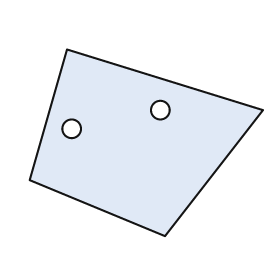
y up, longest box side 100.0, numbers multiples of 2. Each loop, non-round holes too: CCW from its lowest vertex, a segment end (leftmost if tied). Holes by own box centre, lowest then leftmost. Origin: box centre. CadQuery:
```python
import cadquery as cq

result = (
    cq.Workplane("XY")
    .moveTo(8.0, -40.0)
    .lineTo(50.0, 14.0)
    .lineTo(-34.0, 40.0)
    .lineTo(-50.0, -16.0)
    .close()
    .moveTo(-32.0, 6.0)
    .circle(4.0)
    .moveTo(6.0, 14.0)
    .circle(4.0)
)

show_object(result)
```